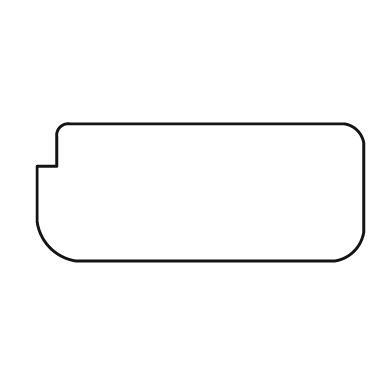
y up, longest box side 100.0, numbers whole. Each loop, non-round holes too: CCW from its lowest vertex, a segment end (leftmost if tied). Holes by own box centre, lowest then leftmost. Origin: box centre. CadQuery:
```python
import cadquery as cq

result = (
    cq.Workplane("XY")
    .moveTo(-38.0, -21.0)
    .lineTo(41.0, -21.0)
    .threePointArc((47.0, -18.0), (50.0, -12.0))
    .lineTo(50.0, 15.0)
    .threePointArc((48.0, 19.0), (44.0, 21.0))
    .lineTo(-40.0, 21.0)
    .threePointArc((-43.0, 20.0), (-44.0, 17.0))
    .lineTo(-44.0, 8.0)
    .lineTo(-50.0, 8.0)
    .lineTo(-50.0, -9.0)
    .threePointArc((-46.0, -17.0), (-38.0, -21.0))
    .close()
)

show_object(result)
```